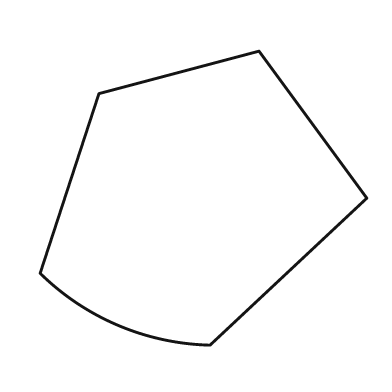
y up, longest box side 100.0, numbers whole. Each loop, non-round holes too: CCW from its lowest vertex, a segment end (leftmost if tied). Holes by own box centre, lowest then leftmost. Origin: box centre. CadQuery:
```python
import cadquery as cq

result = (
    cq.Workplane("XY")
    .moveTo(2.0, -45.0)
    .lineTo(50.0, 0.0)
    .lineTo(17.0, 45.0)
    .lineTo(-32.0, 32.0)
    .lineTo(-50.0, -23.0)
    .threePointArc((-26.0, -39.0), (2.0, -45.0))
    .close()
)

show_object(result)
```